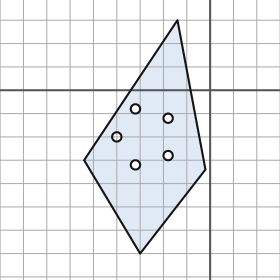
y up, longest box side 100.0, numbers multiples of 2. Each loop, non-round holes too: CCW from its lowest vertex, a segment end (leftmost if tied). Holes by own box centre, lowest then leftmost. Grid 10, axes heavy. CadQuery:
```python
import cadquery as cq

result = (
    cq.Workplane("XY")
    .moveTo(-30.0, -70.0)
    .lineTo(-2.0, -34.0)
    .lineTo(-14.0, 30.0)
    .lineTo(-54.0, -30.0)
    .close()
    .moveTo(-32.0, -32.0)
    .circle(2.0)
    .moveTo(-18.0, -28.0)
    .circle(2.0)
    .moveTo(-40.0, -20.0)
    .circle(2.0)
    .moveTo(-18.0, -12.0)
    .circle(2.0)
    .moveTo(-32.0, -8.0)
    .circle(2.0)
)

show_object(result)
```